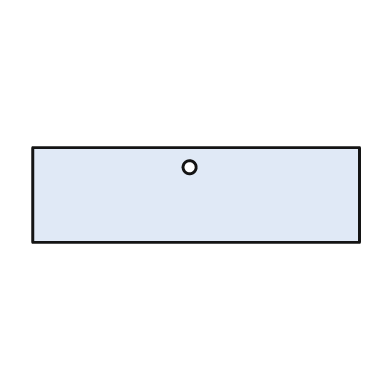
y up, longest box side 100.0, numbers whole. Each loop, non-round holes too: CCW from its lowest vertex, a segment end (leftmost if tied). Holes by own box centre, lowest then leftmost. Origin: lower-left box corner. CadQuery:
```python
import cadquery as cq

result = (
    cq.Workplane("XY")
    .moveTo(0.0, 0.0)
    .lineTo(100.0, 0.0)
    .lineTo(100.0, 29.0)
    .lineTo(0.0, 29.0)
    .close()
    .moveTo(48.0, 23.0)
    .circle(2.0)
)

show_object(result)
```